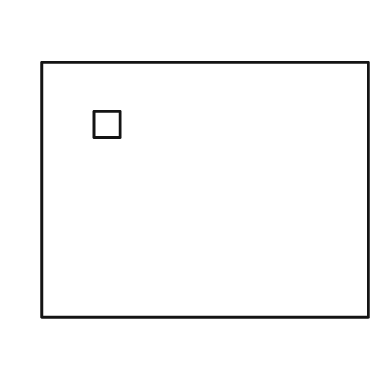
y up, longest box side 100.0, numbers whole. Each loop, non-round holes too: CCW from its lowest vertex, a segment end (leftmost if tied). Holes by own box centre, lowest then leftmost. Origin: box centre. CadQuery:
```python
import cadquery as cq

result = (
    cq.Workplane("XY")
    .moveTo(-50.0, -39.0)
    .lineTo(50.0, -39.0)
    .lineTo(50.0, 39.0)
    .lineTo(-50.0, 39.0)
    .close()
    .moveTo(-34.0, 16.0)
    .lineTo(-26.0, 16.0)
    .lineTo(-26.0, 24.0)
    .lineTo(-34.0, 24.0)
    .close()
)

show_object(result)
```